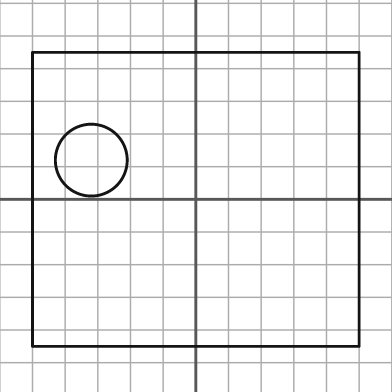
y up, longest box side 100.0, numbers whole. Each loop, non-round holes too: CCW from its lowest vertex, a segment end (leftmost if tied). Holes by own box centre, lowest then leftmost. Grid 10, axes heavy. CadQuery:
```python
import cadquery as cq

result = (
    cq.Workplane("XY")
    .moveTo(-50.0, -45.0)
    .lineTo(50.0, -45.0)
    .lineTo(50.0, 45.0)
    .lineTo(-50.0, 45.0)
    .close()
    .moveTo(-32.0, 12.0)
    .circle(11.0)
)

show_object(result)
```